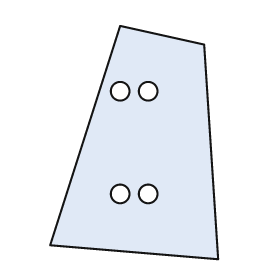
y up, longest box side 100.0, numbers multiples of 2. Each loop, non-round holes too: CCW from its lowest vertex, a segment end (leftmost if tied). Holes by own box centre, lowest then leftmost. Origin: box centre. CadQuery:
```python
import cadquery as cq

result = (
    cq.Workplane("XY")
    .moveTo(36.0, -50.0)
    .lineTo(30.0, 42.0)
    .lineTo(-6.0, 50.0)
    .lineTo(-36.0, -44.0)
    .close()
    .moveTo(-6.0, -22.0)
    .circle(4.0)
    .moveTo(6.0, -22.0)
    .circle(4.0)
    .moveTo(-6.0, 22.0)
    .circle(4.0)
    .moveTo(6.0, 22.0)
    .circle(4.0)
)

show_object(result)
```